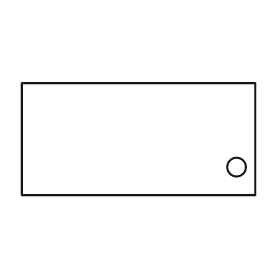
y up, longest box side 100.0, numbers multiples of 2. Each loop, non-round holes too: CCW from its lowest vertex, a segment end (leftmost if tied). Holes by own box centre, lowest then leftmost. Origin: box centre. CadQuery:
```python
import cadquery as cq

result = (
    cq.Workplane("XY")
    .moveTo(-50.0, -24.0)
    .lineTo(50.0, -24.0)
    .lineTo(50.0, 24.0)
    .lineTo(-50.0, 24.0)
    .close()
    .moveTo(42.0, -12.0)
    .circle(4.0)
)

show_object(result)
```